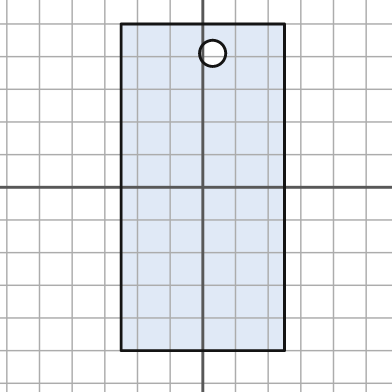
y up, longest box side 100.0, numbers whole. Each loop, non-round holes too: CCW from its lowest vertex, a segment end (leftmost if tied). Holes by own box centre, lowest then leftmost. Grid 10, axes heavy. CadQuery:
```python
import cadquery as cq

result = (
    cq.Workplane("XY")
    .moveTo(-25.0, -50.0)
    .lineTo(25.0, -50.0)
    .lineTo(25.0, 50.0)
    .lineTo(-25.0, 50.0)
    .close()
    .moveTo(3.0, 41.0)
    .circle(4.0)
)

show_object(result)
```